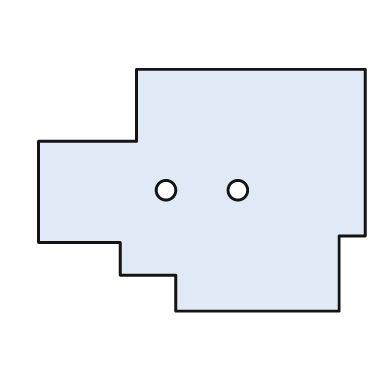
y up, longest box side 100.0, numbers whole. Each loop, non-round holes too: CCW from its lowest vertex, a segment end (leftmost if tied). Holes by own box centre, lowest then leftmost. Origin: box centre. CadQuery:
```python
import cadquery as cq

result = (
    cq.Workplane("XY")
    .moveTo(-8.0, -37.0)
    .lineTo(42.0, -37.0)
    .lineTo(42.0, -14.0)
    .lineTo(50.0, -14.0)
    .lineTo(50.0, 37.0)
    .lineTo(-20.0, 37.0)
    .lineTo(-20.0, 15.0)
    .lineTo(-50.0, 15.0)
    .lineTo(-50.0, -16.0)
    .lineTo(-25.0, -16.0)
    .lineTo(-25.0, -26.0)
    .lineTo(-8.0, -26.0)
    .close()
    .moveTo(-11.0, 0.0)
    .circle(3.0)
    .moveTo(11.0, 0.0)
    .circle(3.0)
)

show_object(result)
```